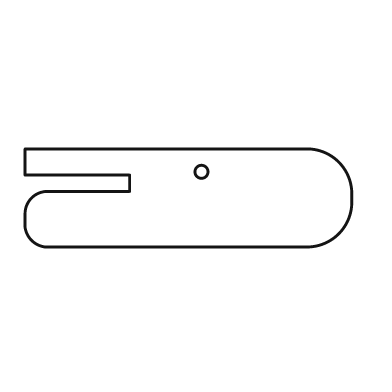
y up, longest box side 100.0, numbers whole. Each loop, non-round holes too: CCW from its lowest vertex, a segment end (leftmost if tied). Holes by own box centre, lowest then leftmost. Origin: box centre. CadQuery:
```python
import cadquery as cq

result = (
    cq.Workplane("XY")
    .moveTo(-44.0, -15.0)
    .lineTo(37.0, -15.0)
    .threePointArc((46.0, -11.0), (50.0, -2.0))
    .lineTo(50.0, 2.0)
    .threePointArc((46.0, 11.0), (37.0, 15.0))
    .lineTo(-50.0, 15.0)
    .lineTo(-50.0, 7.0)
    .lineTo(-18.0, 7.0)
    .lineTo(-18.0, 2.0)
    .lineTo(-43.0, 2.0)
    .threePointArc((-48.0, 0.0), (-50.0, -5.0))
    .lineTo(-50.0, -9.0)
    .threePointArc((-48.0, -13.0), (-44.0, -15.0))
    .close()
    .moveTo(4.0, 8.0)
    .circle(2.0)
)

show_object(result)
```